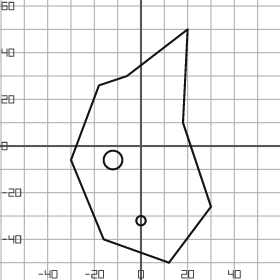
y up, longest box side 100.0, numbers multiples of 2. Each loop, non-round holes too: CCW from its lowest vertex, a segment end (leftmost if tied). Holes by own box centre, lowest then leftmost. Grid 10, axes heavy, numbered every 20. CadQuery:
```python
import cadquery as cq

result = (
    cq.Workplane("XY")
    .moveTo(12.0, -50.0)
    .lineTo(30.0, -26.0)
    .lineTo(18.0, 10.0)
    .lineTo(20.0, 50.0)
    .lineTo(-6.0, 30.0)
    .lineTo(-18.0, 26.0)
    .lineTo(-30.0, -6.0)
    .lineTo(-16.0, -40.0)
    .close()
    .moveTo(0.0, -32.0)
    .circle(2.0)
    .moveTo(-12.0, -6.0)
    .circle(4.0)
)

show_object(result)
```